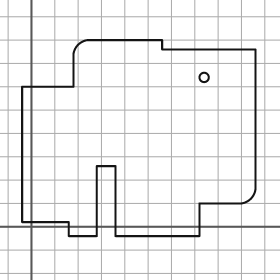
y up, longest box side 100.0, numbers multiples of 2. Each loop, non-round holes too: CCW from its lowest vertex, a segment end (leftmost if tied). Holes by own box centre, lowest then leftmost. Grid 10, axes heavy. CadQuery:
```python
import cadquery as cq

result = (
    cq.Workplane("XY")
    .moveTo(16.0, -4.0)
    .lineTo(28.0, -4.0)
    .lineTo(28.0, 26.0)
    .lineTo(36.0, 26.0)
    .lineTo(36.0, -4.0)
    .lineTo(72.0, -4.0)
    .lineTo(72.0, 10.0)
    .lineTo(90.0, 10.0)
    .threePointArc((94.0, 12.0), (96.0, 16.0))
    .lineTo(96.0, 76.0)
    .lineTo(56.0, 76.0)
    .lineTo(56.0, 80.0)
    .lineTo(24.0, 80.0)
    .threePointArc((20.0, 78.0), (18.0, 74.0))
    .lineTo(18.0, 60.0)
    .lineTo(-4.0, 60.0)
    .lineTo(-4.0, 2.0)
    .lineTo(16.0, 2.0)
    .close()
    .moveTo(74.0, 64.0)
    .circle(2.0)
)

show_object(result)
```